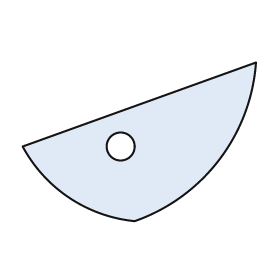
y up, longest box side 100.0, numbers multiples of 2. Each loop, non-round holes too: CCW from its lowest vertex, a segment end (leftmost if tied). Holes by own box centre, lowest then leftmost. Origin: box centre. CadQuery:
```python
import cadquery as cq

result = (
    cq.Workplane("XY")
    .moveTo(-2.0, -34.0)
    .threePointArc((34.0, -8.0), (50.0, 34.0))
    .lineTo(-50.0, -2.0)
    .threePointArc((-30.0, -24.0), (-2.0, -34.0))
    .close()
    .moveTo(-8.0, -2.0)
    .circle(6.0)
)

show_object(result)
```